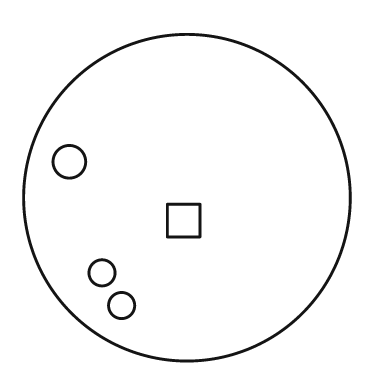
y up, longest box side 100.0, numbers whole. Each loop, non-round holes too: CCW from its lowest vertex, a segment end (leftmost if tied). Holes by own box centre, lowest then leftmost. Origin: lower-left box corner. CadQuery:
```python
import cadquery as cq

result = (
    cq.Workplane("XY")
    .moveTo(50.0, 50.0)
    .circle(50.0)
    .moveTo(30.0, 17.0)
    .circle(4.0)
    .moveTo(24.0, 27.0)
    .circle(4.0)
    .moveTo(44.0, 38.0)
    .lineTo(54.0, 38.0)
    .lineTo(54.0, 48.0)
    .lineTo(44.0, 48.0)
    .close()
    .moveTo(14.0, 61.0)
    .circle(5.0)
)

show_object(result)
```